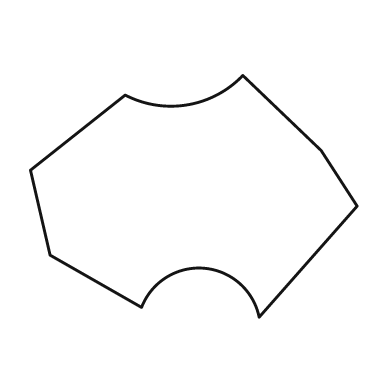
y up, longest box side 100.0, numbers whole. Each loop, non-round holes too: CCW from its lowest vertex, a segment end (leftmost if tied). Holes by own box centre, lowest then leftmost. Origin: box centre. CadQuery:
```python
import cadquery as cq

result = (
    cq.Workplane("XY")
    .moveTo(20.0, -37.0)
    .lineTo(50.0, -3.0)
    .lineTo(39.0, 14.0)
    .lineTo(15.0, 37.0)
    .threePointArc((-2.0, 28.0), (-21.0, 31.0))
    .lineTo(-50.0, 8.0)
    .lineTo(-44.0, -18.0)
    .lineTo(-16.0, -34.0)
    .threePointArc((3.0, -22.0), (20.0, -37.0))
    .close()
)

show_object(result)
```